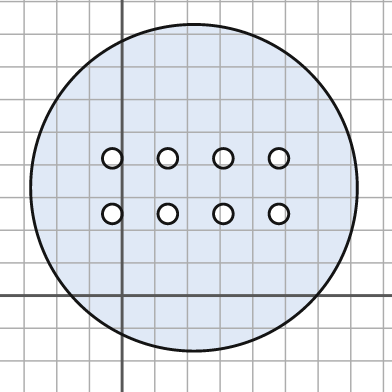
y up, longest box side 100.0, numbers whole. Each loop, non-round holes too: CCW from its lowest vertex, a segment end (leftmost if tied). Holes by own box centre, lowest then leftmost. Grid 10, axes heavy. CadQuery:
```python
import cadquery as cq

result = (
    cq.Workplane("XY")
    .moveTo(22.0, 33.0)
    .circle(50.0)
    .moveTo(-3.0, 25.0)
    .circle(3.0)
    .moveTo(14.0, 25.0)
    .circle(3.0)
    .moveTo(31.0, 25.0)
    .circle(3.0)
    .moveTo(48.0, 25.0)
    .circle(3.0)
    .moveTo(-3.0, 42.0)
    .circle(3.0)
    .moveTo(14.0, 42.0)
    .circle(3.0)
    .moveTo(31.0, 42.0)
    .circle(3.0)
    .moveTo(48.0, 42.0)
    .circle(3.0)
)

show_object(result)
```